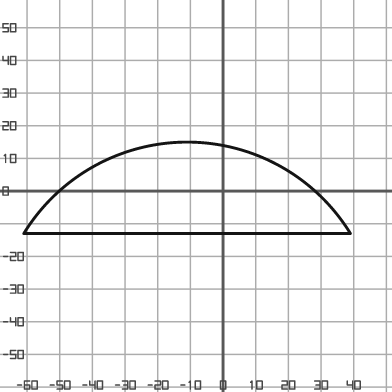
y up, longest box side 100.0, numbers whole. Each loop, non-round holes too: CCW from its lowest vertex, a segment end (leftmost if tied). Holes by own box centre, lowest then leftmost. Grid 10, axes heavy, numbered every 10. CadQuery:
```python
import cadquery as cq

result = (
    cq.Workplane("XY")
    .moveTo(-61.0, -13.0)
    .lineTo(39.0, -13.0)
    .threePointArc((-11.0, 15.0), (-61.0, -13.0))
    .close()
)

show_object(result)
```